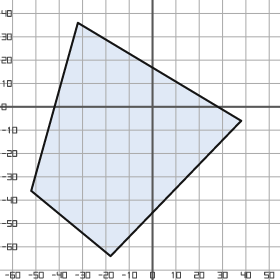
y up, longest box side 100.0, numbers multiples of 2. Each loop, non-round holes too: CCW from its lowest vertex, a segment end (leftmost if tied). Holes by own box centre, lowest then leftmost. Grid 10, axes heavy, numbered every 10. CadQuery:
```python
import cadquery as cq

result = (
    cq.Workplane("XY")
    .moveTo(-18.0, -64.0)
    .lineTo(38.0, -6.0)
    .lineTo(-32.0, 36.0)
    .lineTo(-52.0, -36.0)
    .close()
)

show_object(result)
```